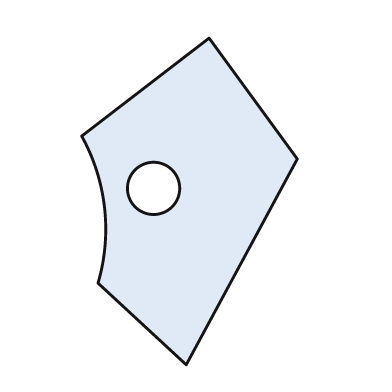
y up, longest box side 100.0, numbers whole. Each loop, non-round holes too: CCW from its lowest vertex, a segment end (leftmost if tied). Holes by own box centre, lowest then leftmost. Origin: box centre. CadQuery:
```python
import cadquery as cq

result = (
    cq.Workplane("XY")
    .moveTo(-1.0, -50.0)
    .lineTo(33.0, 13.0)
    .lineTo(6.0, 50.0)
    .lineTo(-33.0, 20.0)
    .threePointArc((-26.0, -2.0), (-28.0, -25.0))
    .close()
    .moveTo(-11.0, 4.0)
    .circle(8.0)
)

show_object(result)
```